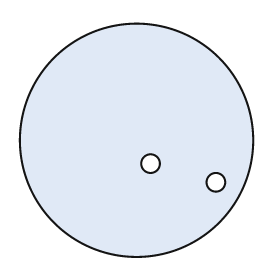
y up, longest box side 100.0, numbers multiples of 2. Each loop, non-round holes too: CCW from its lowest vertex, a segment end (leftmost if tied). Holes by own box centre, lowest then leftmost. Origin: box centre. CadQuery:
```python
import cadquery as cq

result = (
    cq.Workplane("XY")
    .moveTo(0.0, 0.0)
    .circle(50.0)
    .moveTo(34.0, -18.0)
    .circle(4.0)
    .moveTo(6.0, -10.0)
    .circle(4.0)
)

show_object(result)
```